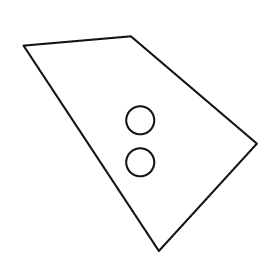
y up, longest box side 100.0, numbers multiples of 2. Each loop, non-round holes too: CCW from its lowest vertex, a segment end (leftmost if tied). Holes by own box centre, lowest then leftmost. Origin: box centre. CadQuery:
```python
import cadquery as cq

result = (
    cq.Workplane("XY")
    .moveTo(8.0, -46.0)
    .lineTo(50.0, 0.0)
    .lineTo(-4.0, 46.0)
    .lineTo(-50.0, 42.0)
    .close()
    .moveTo(0.0, -8.0)
    .circle(6.0)
    .moveTo(0.0, 10.0)
    .circle(6.0)
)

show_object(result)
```